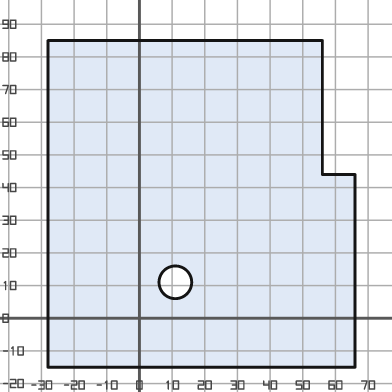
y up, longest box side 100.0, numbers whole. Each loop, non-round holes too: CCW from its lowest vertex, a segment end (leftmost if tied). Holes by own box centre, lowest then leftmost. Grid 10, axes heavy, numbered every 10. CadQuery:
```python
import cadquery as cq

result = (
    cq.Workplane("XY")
    .moveTo(-28.0, -15.0)
    .lineTo(66.0, -15.0)
    .lineTo(66.0, 44.0)
    .lineTo(56.0, 44.0)
    .lineTo(56.0, 85.0)
    .lineTo(-28.0, 85.0)
    .close()
    .moveTo(11.0, 11.0)
    .circle(5.0)
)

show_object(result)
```